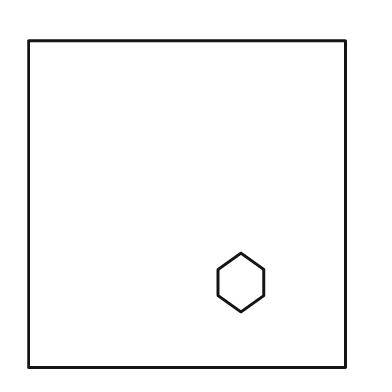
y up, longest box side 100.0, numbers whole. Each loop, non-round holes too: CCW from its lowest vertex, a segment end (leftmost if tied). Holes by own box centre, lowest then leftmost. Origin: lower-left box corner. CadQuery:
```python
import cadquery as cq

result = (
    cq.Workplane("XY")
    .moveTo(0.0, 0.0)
    .lineTo(97.0, 0.0)
    .lineTo(97.0, 100.0)
    .lineTo(0.0, 100.0)
    .close()
    .moveTo(65.0, 17.0)
    .lineTo(72.0, 22.0)
    .lineTo(72.0, 30.0)
    .lineTo(65.0, 35.0)
    .lineTo(58.0, 30.0)
    .lineTo(58.0, 22.0)
    .close()
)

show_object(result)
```